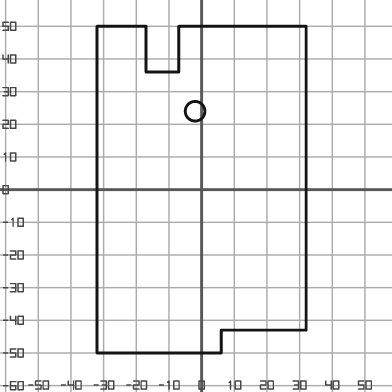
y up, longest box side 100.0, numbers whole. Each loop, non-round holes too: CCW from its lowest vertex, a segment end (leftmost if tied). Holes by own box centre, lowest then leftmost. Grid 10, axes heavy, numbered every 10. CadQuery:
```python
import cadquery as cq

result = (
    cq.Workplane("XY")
    .moveTo(-32.0, -50.0)
    .lineTo(6.0, -50.0)
    .lineTo(6.0, -43.0)
    .lineTo(32.0, -43.0)
    .lineTo(32.0, 50.0)
    .lineTo(-7.0, 50.0)
    .lineTo(-7.0, 36.0)
    .lineTo(-17.0, 36.0)
    .lineTo(-17.0, 50.0)
    .lineTo(-32.0, 50.0)
    .close()
    .moveTo(-2.0, 24.0)
    .circle(3.0)
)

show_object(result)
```